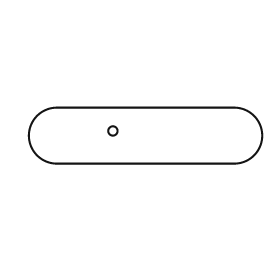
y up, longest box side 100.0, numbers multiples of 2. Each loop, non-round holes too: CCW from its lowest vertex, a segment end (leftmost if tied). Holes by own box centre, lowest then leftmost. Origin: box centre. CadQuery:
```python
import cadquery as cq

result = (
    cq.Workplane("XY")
    .moveTo(-38.0, -12.0)
    .lineTo(38.0, -12.0)
    .threePointArc((50.0, 0.0), (38.0, 12.0))
    .lineTo(-38.0, 12.0)
    .threePointArc((-50.0, 0.0), (-38.0, -12.0))
    .close()
    .moveTo(-14.0, 2.0)
    .circle(2.0)
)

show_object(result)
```